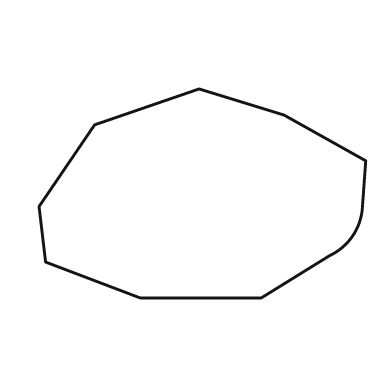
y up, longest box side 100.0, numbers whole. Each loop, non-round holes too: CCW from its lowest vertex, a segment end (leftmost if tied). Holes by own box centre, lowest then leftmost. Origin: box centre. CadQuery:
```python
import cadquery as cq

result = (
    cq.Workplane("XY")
    .moveTo(-19.0, -32.0)
    .lineTo(18.0, -32.0)
    .lineTo(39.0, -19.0)
    .threePointArc((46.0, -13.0), (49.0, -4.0))
    .lineTo(50.0, 10.0)
    .lineTo(25.0, 24.0)
    .lineTo(-1.0, 32.0)
    .lineTo(-33.0, 21.0)
    .lineTo(-50.0, -4.0)
    .lineTo(-48.0, -21.0)
    .close()
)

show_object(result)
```